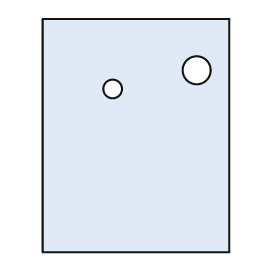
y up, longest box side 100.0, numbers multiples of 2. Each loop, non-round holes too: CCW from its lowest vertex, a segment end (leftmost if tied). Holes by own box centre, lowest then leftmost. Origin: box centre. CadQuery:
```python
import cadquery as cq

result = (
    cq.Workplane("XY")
    .moveTo(-40.0, -50.0)
    .lineTo(40.0, -50.0)
    .lineTo(40.0, 50.0)
    .lineTo(-40.0, 50.0)
    .close()
    .moveTo(-10.0, 20.0)
    .circle(4.0)
    .moveTo(26.0, 28.0)
    .circle(6.0)
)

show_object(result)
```